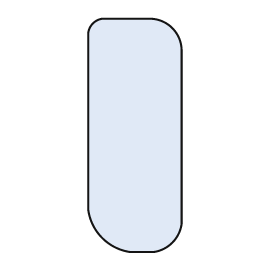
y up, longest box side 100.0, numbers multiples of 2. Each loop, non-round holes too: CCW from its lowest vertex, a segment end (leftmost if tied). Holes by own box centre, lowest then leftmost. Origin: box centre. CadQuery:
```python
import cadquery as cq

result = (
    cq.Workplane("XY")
    .moveTo(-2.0, -50.0)
    .lineTo(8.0, -50.0)
    .threePointArc((16.0, -46.0), (20.0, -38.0))
    .lineTo(20.0, 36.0)
    .threePointArc((16.0, 46.0), (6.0, 50.0))
    .lineTo(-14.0, 50.0)
    .threePointArc((-18.0, 48.0), (-20.0, 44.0))
    .lineTo(-20.0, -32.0)
    .threePointArc((-14.0, -44.0), (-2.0, -50.0))
    .close()
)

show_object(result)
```